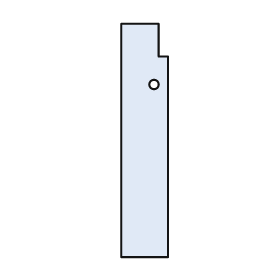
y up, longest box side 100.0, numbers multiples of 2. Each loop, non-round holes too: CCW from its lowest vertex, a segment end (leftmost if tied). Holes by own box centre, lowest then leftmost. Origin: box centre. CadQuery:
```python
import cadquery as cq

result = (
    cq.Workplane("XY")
    .moveTo(-10.0, -50.0)
    .lineTo(10.0, -50.0)
    .lineTo(10.0, 36.0)
    .lineTo(6.0, 36.0)
    .lineTo(6.0, 50.0)
    .lineTo(-10.0, 50.0)
    .close()
    .moveTo(4.0, 24.0)
    .circle(2.0)
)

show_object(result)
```